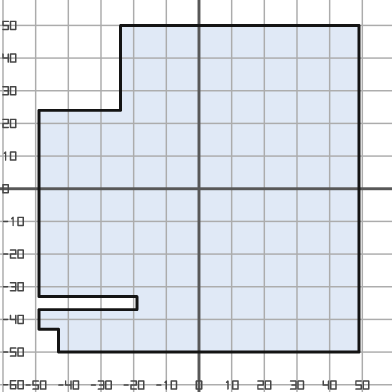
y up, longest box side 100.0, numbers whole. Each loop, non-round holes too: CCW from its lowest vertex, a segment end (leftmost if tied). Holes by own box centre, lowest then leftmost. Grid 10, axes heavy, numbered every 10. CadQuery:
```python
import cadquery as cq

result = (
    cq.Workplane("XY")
    .moveTo(-43.0, -50.0)
    .lineTo(49.0, -50.0)
    .lineTo(49.0, 50.0)
    .lineTo(-24.0, 50.0)
    .lineTo(-24.0, 24.0)
    .lineTo(-49.0, 24.0)
    .lineTo(-49.0, -33.0)
    .lineTo(-19.0, -33.0)
    .lineTo(-19.0, -37.0)
    .lineTo(-49.0, -37.0)
    .lineTo(-49.0, -43.0)
    .lineTo(-43.0, -43.0)
    .close()
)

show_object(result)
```